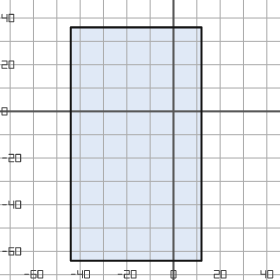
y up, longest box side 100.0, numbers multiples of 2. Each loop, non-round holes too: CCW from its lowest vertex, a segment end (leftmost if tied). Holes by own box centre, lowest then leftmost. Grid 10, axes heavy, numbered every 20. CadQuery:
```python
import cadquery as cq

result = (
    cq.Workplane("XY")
    .moveTo(-44.0, -64.0)
    .lineTo(12.0, -64.0)
    .lineTo(12.0, 36.0)
    .lineTo(-44.0, 36.0)
    .close()
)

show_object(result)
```